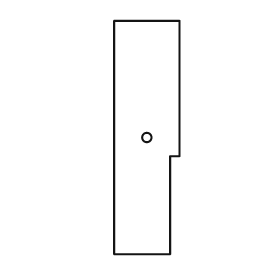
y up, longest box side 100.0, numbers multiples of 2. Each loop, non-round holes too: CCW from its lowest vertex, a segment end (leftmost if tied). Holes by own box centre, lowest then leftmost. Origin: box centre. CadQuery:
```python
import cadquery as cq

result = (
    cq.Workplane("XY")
    .moveTo(-14.0, -50.0)
    .lineTo(10.0, -50.0)
    .lineTo(10.0, -8.0)
    .lineTo(14.0, -8.0)
    .lineTo(14.0, 50.0)
    .lineTo(-14.0, 50.0)
    .close()
    .moveTo(0.0, 0.0)
    .circle(2.0)
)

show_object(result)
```